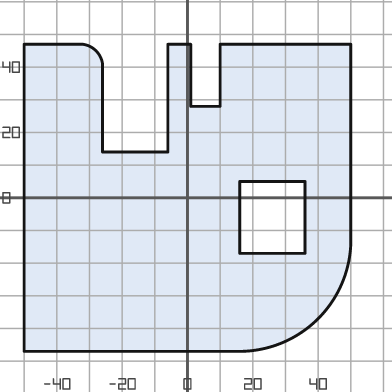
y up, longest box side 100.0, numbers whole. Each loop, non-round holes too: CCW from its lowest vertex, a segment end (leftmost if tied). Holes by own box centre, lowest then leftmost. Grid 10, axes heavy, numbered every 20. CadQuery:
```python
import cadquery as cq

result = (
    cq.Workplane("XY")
    .moveTo(-50.0, -47.0)
    .lineTo(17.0, -47.0)
    .threePointArc((40.0, -37.0), (50.0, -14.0))
    .lineTo(50.0, 47.0)
    .lineTo(10.0, 47.0)
    .lineTo(10.0, 28.0)
    .lineTo(1.0, 28.0)
    .lineTo(1.0, 47.0)
    .lineTo(-6.0, 47.0)
    .lineTo(-6.0, 14.0)
    .lineTo(-26.0, 14.0)
    .lineTo(-26.0, 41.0)
    .threePointArc((-28.0, 45.0), (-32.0, 47.0))
    .lineTo(-50.0, 47.0)
    .close()
    .moveTo(16.0, -17.0)
    .lineTo(36.0, -17.0)
    .lineTo(36.0, 5.0)
    .lineTo(16.0, 5.0)
    .close()
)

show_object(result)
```